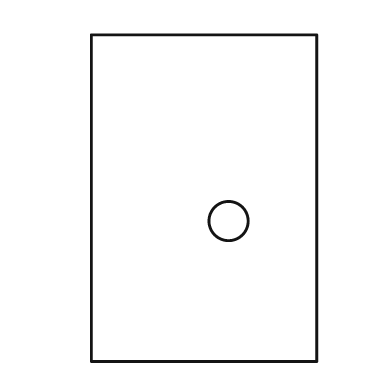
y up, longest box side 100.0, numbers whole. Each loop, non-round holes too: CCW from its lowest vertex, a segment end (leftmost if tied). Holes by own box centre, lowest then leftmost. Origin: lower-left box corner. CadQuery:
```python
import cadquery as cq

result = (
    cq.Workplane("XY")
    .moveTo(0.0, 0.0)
    .lineTo(69.0, 0.0)
    .lineTo(69.0, 100.0)
    .lineTo(0.0, 100.0)
    .close()
    .moveTo(42.0, 43.0)
    .circle(6.0)
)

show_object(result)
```